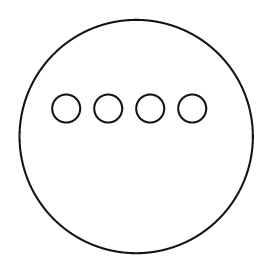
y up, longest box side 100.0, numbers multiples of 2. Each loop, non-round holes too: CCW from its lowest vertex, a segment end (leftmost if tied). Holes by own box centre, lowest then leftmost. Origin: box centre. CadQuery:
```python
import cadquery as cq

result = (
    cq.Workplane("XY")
    .moveTo(0.0, 0.0)
    .circle(50.0)
    .moveTo(-30.0, 12.0)
    .circle(6.0)
    .moveTo(-12.0, 12.0)
    .circle(6.0)
    .moveTo(6.0, 12.0)
    .circle(6.0)
    .moveTo(24.0, 12.0)
    .circle(6.0)
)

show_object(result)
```